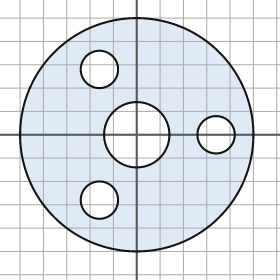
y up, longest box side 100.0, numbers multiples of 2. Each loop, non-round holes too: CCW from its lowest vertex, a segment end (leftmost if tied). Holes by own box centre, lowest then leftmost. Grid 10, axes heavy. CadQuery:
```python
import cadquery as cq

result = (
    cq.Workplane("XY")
    .moveTo(0.0, 0.0)
    .circle(50.0)
    .moveTo(-16.0, -28.0)
    .circle(8.0)
    .moveTo(0.0, 0.0)
    .circle(14.0)
    .moveTo(34.0, 0.0)
    .circle(8.0)
    .moveTo(-16.0, 28.0)
    .circle(8.0)
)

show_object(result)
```